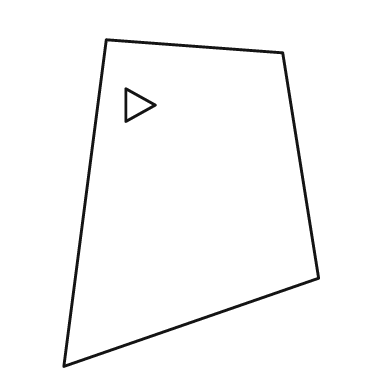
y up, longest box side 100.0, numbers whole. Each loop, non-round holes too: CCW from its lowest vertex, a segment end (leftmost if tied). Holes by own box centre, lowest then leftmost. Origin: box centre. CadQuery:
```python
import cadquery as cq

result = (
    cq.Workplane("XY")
    .moveTo(-39.0, -50.0)
    .lineTo(39.0, -23.0)
    .lineTo(28.0, 46.0)
    .lineTo(-26.0, 50.0)
    .close()
    .moveTo(-20.0, 25.0)
    .lineTo(-11.0, 30.0)
    .lineTo(-20.0, 35.0)
    .close()
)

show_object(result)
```